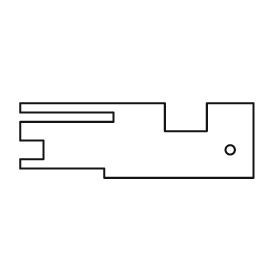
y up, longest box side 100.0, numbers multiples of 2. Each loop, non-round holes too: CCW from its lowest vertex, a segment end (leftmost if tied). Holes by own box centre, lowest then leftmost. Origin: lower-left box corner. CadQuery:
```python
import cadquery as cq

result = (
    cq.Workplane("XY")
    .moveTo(36.0, 0.0)
    .lineTo(100.0, 0.0)
    .lineTo(100.0, 32.0)
    .lineTo(80.0, 32.0)
    .lineTo(80.0, 20.0)
    .lineTo(62.0, 20.0)
    .lineTo(62.0, 32.0)
    .lineTo(0.0, 32.0)
    .lineTo(0.0, 28.0)
    .lineTo(40.0, 28.0)
    .lineTo(40.0, 24.0)
    .lineTo(0.0, 24.0)
    .lineTo(0.0, 16.0)
    .lineTo(10.0, 16.0)
    .lineTo(10.0, 8.0)
    .lineTo(0.0, 8.0)
    .lineTo(0.0, 4.0)
    .lineTo(36.0, 4.0)
    .close()
    .moveTo(90.0, 12.0)
    .circle(2.0)
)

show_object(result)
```